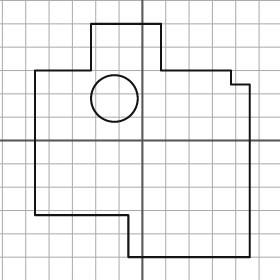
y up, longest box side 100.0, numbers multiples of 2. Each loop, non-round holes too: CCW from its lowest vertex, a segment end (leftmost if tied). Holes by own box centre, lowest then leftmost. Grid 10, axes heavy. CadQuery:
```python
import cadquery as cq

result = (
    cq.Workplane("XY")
    .moveTo(-6.0, -50.0)
    .lineTo(46.0, -50.0)
    .lineTo(46.0, 24.0)
    .lineTo(38.0, 24.0)
    .lineTo(38.0, 30.0)
    .lineTo(8.0, 30.0)
    .lineTo(8.0, 50.0)
    .lineTo(-22.0, 50.0)
    .lineTo(-22.0, 30.0)
    .lineTo(-46.0, 30.0)
    .lineTo(-46.0, -32.0)
    .lineTo(-6.0, -32.0)
    .close()
    .moveTo(-12.0, 18.0)
    .circle(10.0)
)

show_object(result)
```